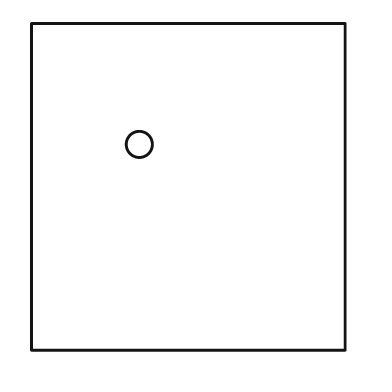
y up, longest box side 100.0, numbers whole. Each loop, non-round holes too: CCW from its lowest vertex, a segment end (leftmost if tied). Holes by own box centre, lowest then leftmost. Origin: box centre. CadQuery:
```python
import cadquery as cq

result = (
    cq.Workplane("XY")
    .moveTo(-48.0, -50.0)
    .lineTo(48.0, -50.0)
    .lineTo(48.0, 50.0)
    .lineTo(-48.0, 50.0)
    .close()
    .moveTo(-15.0, 13.0)
    .circle(4.0)
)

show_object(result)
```